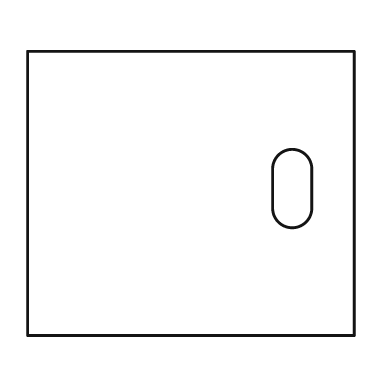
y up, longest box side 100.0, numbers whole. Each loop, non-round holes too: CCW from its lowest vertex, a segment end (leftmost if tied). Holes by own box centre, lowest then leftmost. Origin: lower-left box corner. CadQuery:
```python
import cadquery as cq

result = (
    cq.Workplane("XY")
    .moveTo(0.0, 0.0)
    .lineTo(100.0, 0.0)
    .lineTo(100.0, 87.0)
    .lineTo(0.0, 87.0)
    .close()
    .moveTo(75.0, 39.0)
    .threePointArc((81.0, 33.0), (87.0, 39.0))
    .lineTo(87.0, 51.0)
    .threePointArc((81.0, 57.0), (75.0, 51.0))
    .close()
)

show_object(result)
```